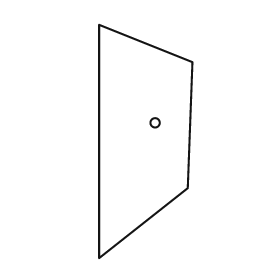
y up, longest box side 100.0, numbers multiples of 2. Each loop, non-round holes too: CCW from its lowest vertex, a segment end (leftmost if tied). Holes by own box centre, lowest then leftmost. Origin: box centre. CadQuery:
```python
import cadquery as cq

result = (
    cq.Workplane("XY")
    .moveTo(-20.0, -50.0)
    .lineTo(18.0, -20.0)
    .lineTo(20.0, 34.0)
    .lineTo(-20.0, 50.0)
    .close()
    .moveTo(4.0, 8.0)
    .circle(2.0)
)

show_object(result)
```